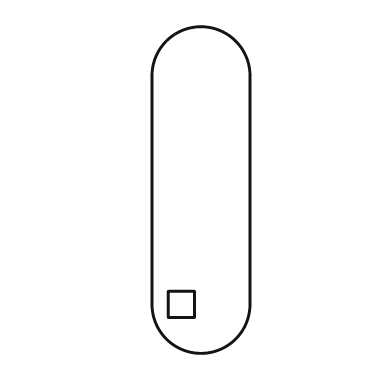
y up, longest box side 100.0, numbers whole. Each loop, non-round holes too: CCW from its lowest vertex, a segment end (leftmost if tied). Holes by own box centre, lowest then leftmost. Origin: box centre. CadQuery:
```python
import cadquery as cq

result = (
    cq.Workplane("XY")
    .moveTo(-15.0, -35.0)
    .threePointArc((0.0, -50.0), (15.0, -35.0))
    .lineTo(15.0, 35.0)
    .threePointArc((0.0, 50.0), (-15.0, 35.0))
    .close()
    .moveTo(-10.0, -39.0)
    .lineTo(-2.0, -39.0)
    .lineTo(-2.0, -31.0)
    .lineTo(-10.0, -31.0)
    .close()
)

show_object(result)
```